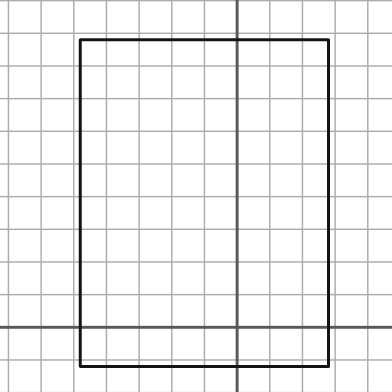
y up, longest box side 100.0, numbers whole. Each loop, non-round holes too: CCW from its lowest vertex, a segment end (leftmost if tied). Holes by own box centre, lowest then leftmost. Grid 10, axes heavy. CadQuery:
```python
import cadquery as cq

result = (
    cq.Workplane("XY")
    .moveTo(-48.0, -12.0)
    .lineTo(28.0, -12.0)
    .lineTo(28.0, 88.0)
    .lineTo(-48.0, 88.0)
    .close()
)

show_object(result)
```